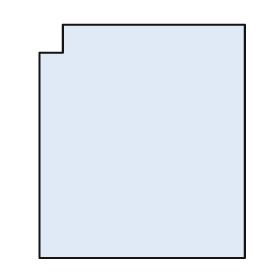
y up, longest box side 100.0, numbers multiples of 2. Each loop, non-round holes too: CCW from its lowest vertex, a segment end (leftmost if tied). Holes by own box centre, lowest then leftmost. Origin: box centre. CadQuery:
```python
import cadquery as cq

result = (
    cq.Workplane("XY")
    .moveTo(-44.0, -50.0)
    .lineTo(44.0, -50.0)
    .lineTo(44.0, 50.0)
    .lineTo(-34.0, 50.0)
    .lineTo(-34.0, 38.0)
    .lineTo(-44.0, 38.0)
    .close()
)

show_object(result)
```